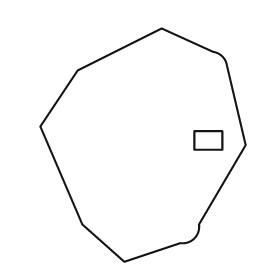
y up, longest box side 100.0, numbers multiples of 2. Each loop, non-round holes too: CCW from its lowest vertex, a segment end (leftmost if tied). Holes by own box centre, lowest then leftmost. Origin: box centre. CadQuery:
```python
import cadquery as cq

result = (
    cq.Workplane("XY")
    .moveTo(-8.0, -50.0)
    .lineTo(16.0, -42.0)
    .threePointArc((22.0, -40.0), (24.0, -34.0))
    .lineTo(44.0, 0.0)
    .lineTo(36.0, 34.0)
    .threePointArc((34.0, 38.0), (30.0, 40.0))
    .lineTo(8.0, 50.0)
    .lineTo(-28.0, 32.0)
    .lineTo(-44.0, 8.0)
    .lineTo(-26.0, -34.0)
    .close()
    .moveTo(22.0, -2.0)
    .lineTo(34.0, -2.0)
    .lineTo(34.0, 6.0)
    .lineTo(22.0, 6.0)
    .close()
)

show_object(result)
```